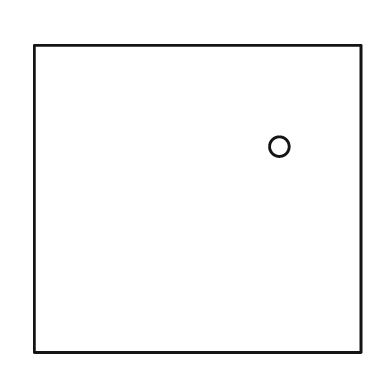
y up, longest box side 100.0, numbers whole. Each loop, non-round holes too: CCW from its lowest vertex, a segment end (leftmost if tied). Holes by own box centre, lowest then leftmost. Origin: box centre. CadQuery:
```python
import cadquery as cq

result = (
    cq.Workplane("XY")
    .moveTo(-50.0, -47.0)
    .lineTo(50.0, -47.0)
    .lineTo(50.0, 47.0)
    .lineTo(-50.0, 47.0)
    .close()
    .moveTo(25.0, 16.0)
    .circle(3.0)
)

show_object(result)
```